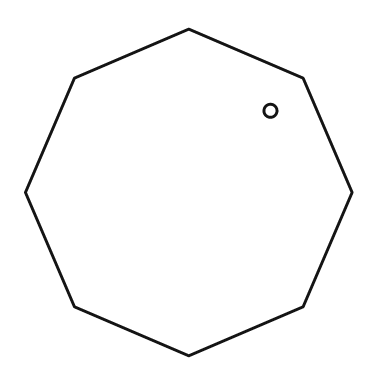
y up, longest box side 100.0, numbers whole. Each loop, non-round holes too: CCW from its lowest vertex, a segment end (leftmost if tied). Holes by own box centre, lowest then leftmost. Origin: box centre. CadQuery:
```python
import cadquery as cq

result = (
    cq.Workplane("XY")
    .moveTo(0.0, -50.0)
    .lineTo(35.0, -35.0)
    .lineTo(50.0, 0.0)
    .lineTo(35.0, 35.0)
    .lineTo(0.0, 50.0)
    .lineTo(-35.0, 35.0)
    .lineTo(-50.0, 0.0)
    .lineTo(-35.0, -35.0)
    .close()
    .moveTo(25.0, 25.0)
    .circle(2.0)
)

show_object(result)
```